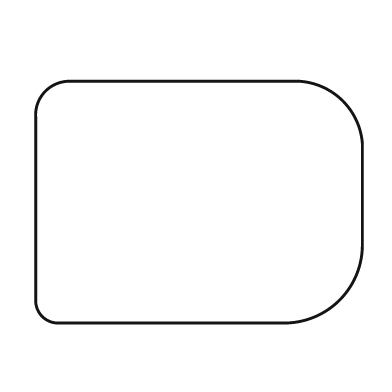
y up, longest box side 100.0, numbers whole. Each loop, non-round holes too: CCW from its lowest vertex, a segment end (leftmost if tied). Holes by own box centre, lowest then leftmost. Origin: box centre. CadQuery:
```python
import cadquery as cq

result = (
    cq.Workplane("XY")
    .moveTo(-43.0, -37.0)
    .lineTo(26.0, -37.0)
    .threePointArc((43.0, -30.0), (50.0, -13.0))
    .lineTo(50.0, 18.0)
    .threePointArc((44.0, 31.0), (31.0, 37.0))
    .lineTo(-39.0, 37.0)
    .threePointArc((-47.0, 34.0), (-50.0, 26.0))
    .lineTo(-50.0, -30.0)
    .threePointArc((-48.0, -35.0), (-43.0, -37.0))
    .close()
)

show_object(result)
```